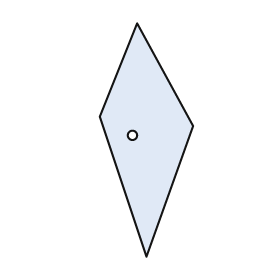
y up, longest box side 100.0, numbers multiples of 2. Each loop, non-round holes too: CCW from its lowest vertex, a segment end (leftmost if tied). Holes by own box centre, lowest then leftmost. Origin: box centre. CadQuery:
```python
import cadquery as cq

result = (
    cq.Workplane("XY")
    .moveTo(0.0, -50.0)
    .lineTo(20.0, 6.0)
    .lineTo(-4.0, 50.0)
    .lineTo(-20.0, 10.0)
    .close()
    .moveTo(-6.0, 2.0)
    .circle(2.0)
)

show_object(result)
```